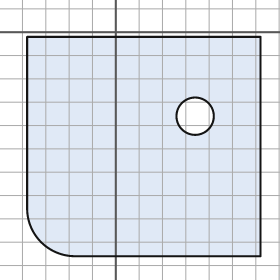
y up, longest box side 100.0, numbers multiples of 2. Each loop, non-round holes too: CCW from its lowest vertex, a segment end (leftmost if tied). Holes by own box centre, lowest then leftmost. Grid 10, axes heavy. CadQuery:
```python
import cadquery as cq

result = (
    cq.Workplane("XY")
    .moveTo(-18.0, -96.0)
    .lineTo(62.0, -96.0)
    .lineTo(62.0, -2.0)
    .lineTo(-38.0, -2.0)
    .lineTo(-38.0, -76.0)
    .threePointArc((-32.0, -90.0), (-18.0, -96.0))
    .close()
    .moveTo(34.0, -36.0)
    .circle(8.0)
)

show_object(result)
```